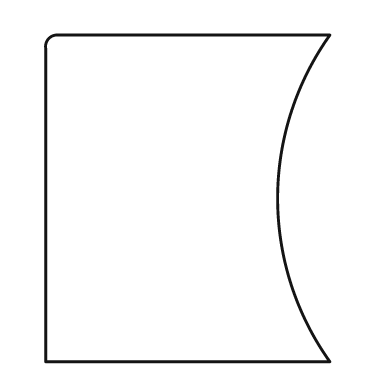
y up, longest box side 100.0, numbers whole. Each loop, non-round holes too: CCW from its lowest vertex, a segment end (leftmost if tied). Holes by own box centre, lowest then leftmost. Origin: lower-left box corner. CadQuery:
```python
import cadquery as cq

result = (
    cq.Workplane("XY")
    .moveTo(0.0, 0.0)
    .lineTo(87.0, 0.0)
    .threePointArc((71.0, 50.0), (87.0, 100.0))
    .lineTo(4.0, 100.0)
    .threePointArc((1.0, 99.0), (0.0, 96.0))
    .close()
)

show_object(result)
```